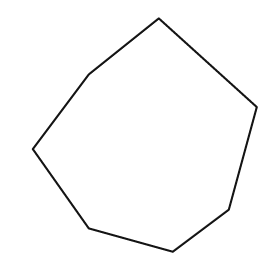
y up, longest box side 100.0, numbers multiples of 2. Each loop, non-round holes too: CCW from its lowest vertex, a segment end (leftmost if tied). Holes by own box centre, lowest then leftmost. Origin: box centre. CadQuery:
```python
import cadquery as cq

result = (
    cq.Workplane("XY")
    .moveTo(12.0, -50.0)
    .lineTo(36.0, -32.0)
    .lineTo(48.0, 12.0)
    .lineTo(6.0, 50.0)
    .lineTo(-24.0, 26.0)
    .lineTo(-48.0, -6.0)
    .lineTo(-24.0, -40.0)
    .close()
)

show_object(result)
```